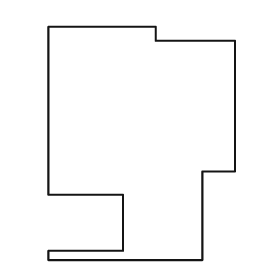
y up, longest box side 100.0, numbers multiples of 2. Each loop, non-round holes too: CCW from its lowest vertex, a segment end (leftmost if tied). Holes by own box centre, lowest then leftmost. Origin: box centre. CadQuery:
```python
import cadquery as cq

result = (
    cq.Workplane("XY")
    .moveTo(-40.0, -50.0)
    .lineTo(26.0, -50.0)
    .lineTo(26.0, -12.0)
    .lineTo(40.0, -12.0)
    .lineTo(40.0, 44.0)
    .lineTo(6.0, 44.0)
    .lineTo(6.0, 50.0)
    .lineTo(-40.0, 50.0)
    .lineTo(-40.0, -22.0)
    .lineTo(-8.0, -22.0)
    .lineTo(-8.0, -46.0)
    .lineTo(-40.0, -46.0)
    .close()
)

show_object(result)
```